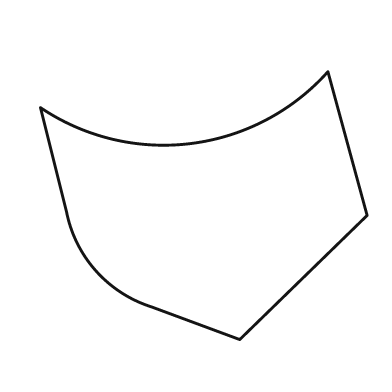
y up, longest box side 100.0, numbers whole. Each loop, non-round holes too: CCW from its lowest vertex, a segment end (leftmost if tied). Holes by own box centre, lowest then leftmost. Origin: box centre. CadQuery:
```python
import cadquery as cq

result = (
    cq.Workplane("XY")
    .moveTo(11.0, -41.0)
    .lineTo(50.0, -3.0)
    .lineTo(38.0, 41.0)
    .threePointArc((-4.0, 19.0), (-50.0, 30.0))
    .lineTo(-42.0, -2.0)
    .threePointArc((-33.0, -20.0), (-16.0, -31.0))
    .close()
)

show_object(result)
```